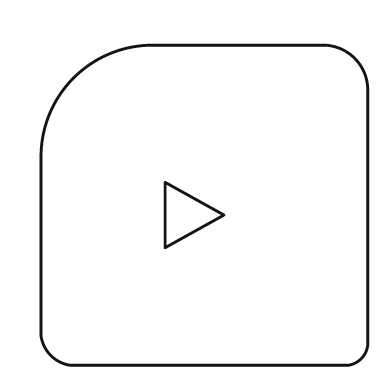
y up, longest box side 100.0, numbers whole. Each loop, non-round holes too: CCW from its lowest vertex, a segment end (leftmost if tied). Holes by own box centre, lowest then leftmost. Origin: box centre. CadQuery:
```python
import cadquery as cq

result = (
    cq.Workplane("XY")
    .moveTo(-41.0, -49.0)
    .lineTo(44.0, -49.0)
    .threePointArc((48.0, -47.0), (50.0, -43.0))
    .lineTo(50.0, 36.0)
    .threePointArc((46.0, 45.0), (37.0, 49.0))
    .lineTo(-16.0, 49.0)
    .threePointArc((-40.0, 39.0), (-50.0, 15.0))
    .lineTo(-50.0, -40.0)
    .threePointArc((-47.0, -46.0), (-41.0, -49.0))
    .close()
    .moveTo(-12.0, -13.0)
    .lineTo(6.0, -3.0)
    .lineTo(-12.0, 7.0)
    .close()
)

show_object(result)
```